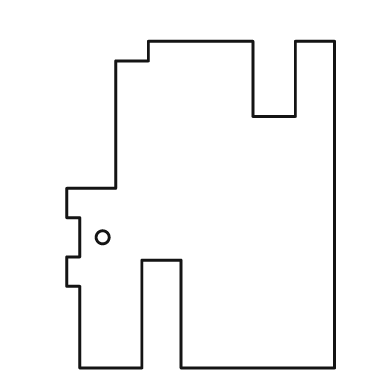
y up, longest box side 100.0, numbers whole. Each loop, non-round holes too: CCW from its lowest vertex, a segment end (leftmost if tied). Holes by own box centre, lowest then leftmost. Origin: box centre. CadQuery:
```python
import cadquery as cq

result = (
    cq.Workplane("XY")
    .moveTo(-37.0, -50.0)
    .lineTo(-18.0, -50.0)
    .lineTo(-18.0, -17.0)
    .lineTo(-6.0, -17.0)
    .lineTo(-6.0, -50.0)
    .lineTo(41.0, -50.0)
    .lineTo(41.0, 50.0)
    .lineTo(29.0, 50.0)
    .lineTo(29.0, 27.0)
    .lineTo(16.0, 27.0)
    .lineTo(16.0, 50.0)
    .lineTo(-16.0, 50.0)
    .lineTo(-16.0, 44.0)
    .lineTo(-26.0, 44.0)
    .lineTo(-26.0, 5.0)
    .lineTo(-41.0, 5.0)
    .lineTo(-41.0, -4.0)
    .lineTo(-37.0, -4.0)
    .lineTo(-37.0, -16.0)
    .lineTo(-41.0, -16.0)
    .lineTo(-41.0, -25.0)
    .lineTo(-37.0, -25.0)
    .close()
    .moveTo(-30.0, -10.0)
    .circle(2.0)
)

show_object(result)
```